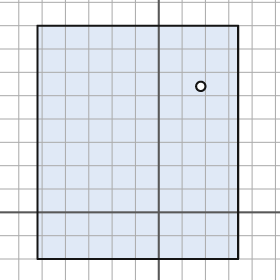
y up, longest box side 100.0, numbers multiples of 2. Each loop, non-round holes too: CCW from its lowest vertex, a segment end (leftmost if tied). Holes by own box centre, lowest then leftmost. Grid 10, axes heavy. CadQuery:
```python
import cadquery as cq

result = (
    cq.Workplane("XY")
    .moveTo(-52.0, -20.0)
    .lineTo(34.0, -20.0)
    .lineTo(34.0, 80.0)
    .lineTo(-52.0, 80.0)
    .close()
    .moveTo(18.0, 54.0)
    .circle(2.0)
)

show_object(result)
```